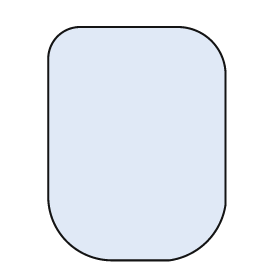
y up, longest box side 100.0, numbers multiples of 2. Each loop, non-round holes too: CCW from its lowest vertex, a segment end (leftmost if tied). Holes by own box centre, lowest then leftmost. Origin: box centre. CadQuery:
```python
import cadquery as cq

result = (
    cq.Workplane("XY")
    .moveTo(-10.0, -50.0)
    .lineTo(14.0, -50.0)
    .threePointArc((30.0, -42.0), (38.0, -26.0))
    .lineTo(38.0, 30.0)
    .threePointArc((32.0, 44.0), (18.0, 50.0))
    .lineTo(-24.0, 50.0)
    .threePointArc((-34.0, 46.0), (-38.0, 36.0))
    .lineTo(-38.0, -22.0)
    .threePointArc((-30.0, -42.0), (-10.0, -50.0))
    .close()
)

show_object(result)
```